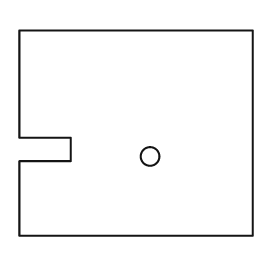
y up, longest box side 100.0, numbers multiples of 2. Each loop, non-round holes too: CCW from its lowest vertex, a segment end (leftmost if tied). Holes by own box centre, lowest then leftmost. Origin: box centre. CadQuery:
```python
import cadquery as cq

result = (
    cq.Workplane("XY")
    .moveTo(-50.0, -44.0)
    .lineTo(50.0, -44.0)
    .lineTo(50.0, 44.0)
    .lineTo(-50.0, 44.0)
    .lineTo(-50.0, -2.0)
    .lineTo(-28.0, -2.0)
    .lineTo(-28.0, -12.0)
    .lineTo(-50.0, -12.0)
    .close()
    .moveTo(6.0, -10.0)
    .circle(4.0)
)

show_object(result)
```